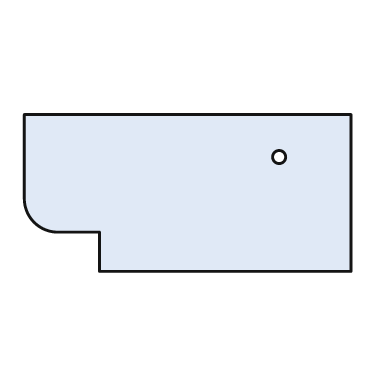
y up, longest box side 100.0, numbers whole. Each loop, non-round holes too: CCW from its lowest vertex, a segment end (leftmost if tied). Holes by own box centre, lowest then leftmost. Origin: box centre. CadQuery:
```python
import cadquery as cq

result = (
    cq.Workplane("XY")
    .moveTo(-27.0, -24.0)
    .lineTo(50.0, -24.0)
    .lineTo(50.0, 24.0)
    .lineTo(-50.0, 24.0)
    .lineTo(-50.0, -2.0)
    .threePointArc((-47.0, -9.0), (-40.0, -12.0))
    .lineTo(-27.0, -12.0)
    .close()
    .moveTo(28.0, 11.0)
    .circle(2.0)
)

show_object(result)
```